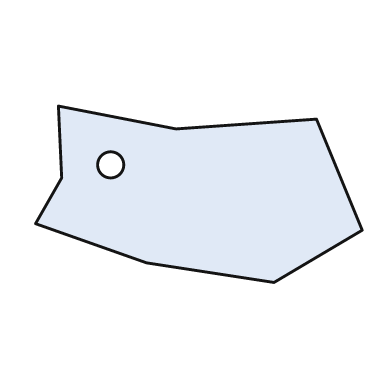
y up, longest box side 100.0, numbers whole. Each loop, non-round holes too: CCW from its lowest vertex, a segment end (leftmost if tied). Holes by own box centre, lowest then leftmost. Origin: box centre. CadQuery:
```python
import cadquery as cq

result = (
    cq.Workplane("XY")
    .moveTo(23.0, -27.0)
    .lineTo(50.0, -11.0)
    .lineTo(36.0, 23.0)
    .lineTo(-7.0, 20.0)
    .lineTo(-43.0, 27.0)
    .lineTo(-42.0, 5.0)
    .lineTo(-50.0, -9.0)
    .lineTo(-16.0, -21.0)
    .close()
    .moveTo(-27.0, 9.0)
    .circle(4.0)
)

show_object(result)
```